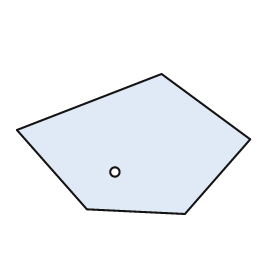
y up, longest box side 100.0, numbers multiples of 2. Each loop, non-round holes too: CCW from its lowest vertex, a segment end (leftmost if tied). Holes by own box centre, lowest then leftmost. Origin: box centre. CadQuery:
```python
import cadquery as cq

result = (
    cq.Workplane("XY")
    .moveTo(22.0, -30.0)
    .lineTo(50.0, 2.0)
    .lineTo(12.0, 30.0)
    .lineTo(-50.0, 6.0)
    .lineTo(-20.0, -28.0)
    .close()
    .moveTo(-8.0, -12.0)
    .circle(2.0)
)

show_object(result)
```